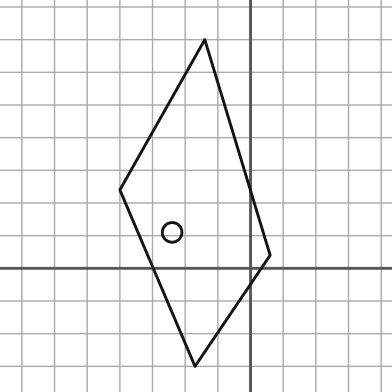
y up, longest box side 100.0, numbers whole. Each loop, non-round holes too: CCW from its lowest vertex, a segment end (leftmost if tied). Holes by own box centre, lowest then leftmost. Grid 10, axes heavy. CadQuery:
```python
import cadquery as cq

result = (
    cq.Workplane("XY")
    .moveTo(-17.0, -30.0)
    .lineTo(6.0, 4.0)
    .lineTo(-14.0, 70.0)
    .lineTo(-40.0, 24.0)
    .close()
    .moveTo(-24.0, 11.0)
    .circle(3.0)
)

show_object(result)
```